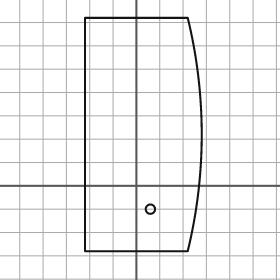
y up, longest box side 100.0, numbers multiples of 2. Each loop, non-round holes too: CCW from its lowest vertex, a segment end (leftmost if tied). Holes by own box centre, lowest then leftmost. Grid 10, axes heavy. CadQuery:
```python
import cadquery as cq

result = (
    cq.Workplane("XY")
    .moveTo(-22.0, -28.0)
    .lineTo(22.0, -28.0)
    .threePointArc((28.0, 22.0), (22.0, 72.0))
    .lineTo(-22.0, 72.0)
    .close()
    .moveTo(6.0, -10.0)
    .circle(2.0)
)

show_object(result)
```